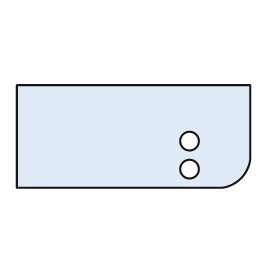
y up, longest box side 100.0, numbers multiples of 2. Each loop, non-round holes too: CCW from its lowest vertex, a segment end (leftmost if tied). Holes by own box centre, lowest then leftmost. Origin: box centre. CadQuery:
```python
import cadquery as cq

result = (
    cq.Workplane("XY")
    .moveTo(-50.0, -22.0)
    .lineTo(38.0, -22.0)
    .threePointArc((46.0, -18.0), (50.0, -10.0))
    .lineTo(50.0, 22.0)
    .lineTo(-50.0, 22.0)
    .close()
    .moveTo(24.0, -14.0)
    .circle(4.0)
    .moveTo(24.0, -2.0)
    .circle(4.0)
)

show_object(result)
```